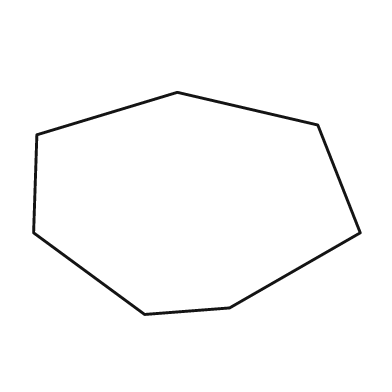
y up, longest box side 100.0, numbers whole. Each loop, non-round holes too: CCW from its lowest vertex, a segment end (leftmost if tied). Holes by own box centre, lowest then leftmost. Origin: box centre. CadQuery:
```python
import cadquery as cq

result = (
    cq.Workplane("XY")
    .moveTo(-16.0, -34.0)
    .lineTo(10.0, -32.0)
    .lineTo(50.0, -9.0)
    .lineTo(37.0, 24.0)
    .lineTo(-6.0, 34.0)
    .lineTo(-49.0, 21.0)
    .lineTo(-50.0, -9.0)
    .close()
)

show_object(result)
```